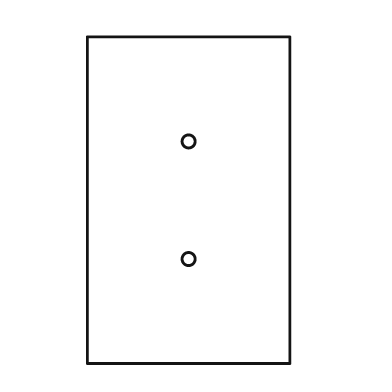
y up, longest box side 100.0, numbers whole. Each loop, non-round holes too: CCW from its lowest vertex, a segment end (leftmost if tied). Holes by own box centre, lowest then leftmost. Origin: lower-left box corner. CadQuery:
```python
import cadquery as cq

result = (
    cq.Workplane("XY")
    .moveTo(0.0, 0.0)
    .lineTo(62.0, 0.0)
    .lineTo(62.0, 100.0)
    .lineTo(0.0, 100.0)
    .close()
    .moveTo(31.0, 32.0)
    .circle(2.0)
    .moveTo(31.0, 68.0)
    .circle(2.0)
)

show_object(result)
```